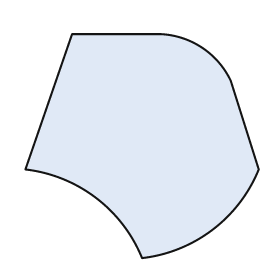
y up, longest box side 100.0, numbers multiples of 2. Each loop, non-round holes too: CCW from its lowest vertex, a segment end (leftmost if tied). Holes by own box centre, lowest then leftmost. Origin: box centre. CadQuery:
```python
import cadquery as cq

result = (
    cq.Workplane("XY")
    .moveTo(0.0, -48.0)
    .threePointArc((30.0, -36.0), (50.0, -10.0))
    .lineTo(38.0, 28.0)
    .threePointArc((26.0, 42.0), (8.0, 48.0))
    .lineTo(-30.0, 48.0)
    .lineTo(-50.0, -10.0)
    .threePointArc((-20.0, -22.0), (0.0, -48.0))
    .close()
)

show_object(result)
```